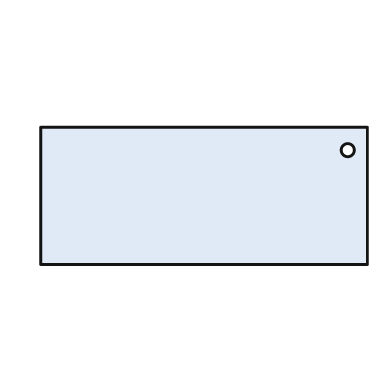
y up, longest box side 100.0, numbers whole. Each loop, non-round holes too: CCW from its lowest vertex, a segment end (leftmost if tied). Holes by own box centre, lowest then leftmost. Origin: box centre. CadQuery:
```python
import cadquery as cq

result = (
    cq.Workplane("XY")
    .moveTo(-50.0, -21.0)
    .lineTo(50.0, -21.0)
    .lineTo(50.0, 21.0)
    .lineTo(-50.0, 21.0)
    .close()
    .moveTo(44.0, 14.0)
    .circle(2.0)
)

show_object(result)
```